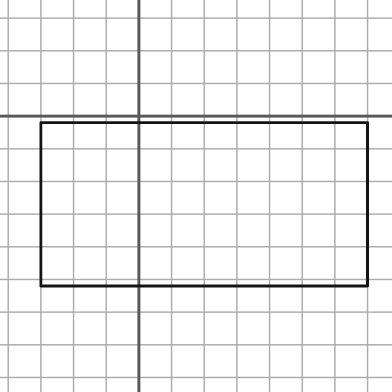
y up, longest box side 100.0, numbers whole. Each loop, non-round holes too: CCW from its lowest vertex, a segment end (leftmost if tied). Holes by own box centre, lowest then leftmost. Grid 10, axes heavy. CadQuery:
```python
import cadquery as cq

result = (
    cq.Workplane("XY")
    .moveTo(-30.0, -52.0)
    .lineTo(70.0, -52.0)
    .lineTo(70.0, -2.0)
    .lineTo(-30.0, -2.0)
    .close()
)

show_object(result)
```